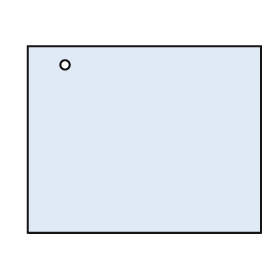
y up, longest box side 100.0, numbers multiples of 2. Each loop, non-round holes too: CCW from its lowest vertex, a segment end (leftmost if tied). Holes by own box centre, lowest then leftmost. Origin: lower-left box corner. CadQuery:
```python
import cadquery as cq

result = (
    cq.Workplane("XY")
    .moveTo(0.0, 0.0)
    .lineTo(100.0, 0.0)
    .lineTo(100.0, 80.0)
    .lineTo(0.0, 80.0)
    .close()
    .moveTo(16.0, 72.0)
    .circle(2.0)
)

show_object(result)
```